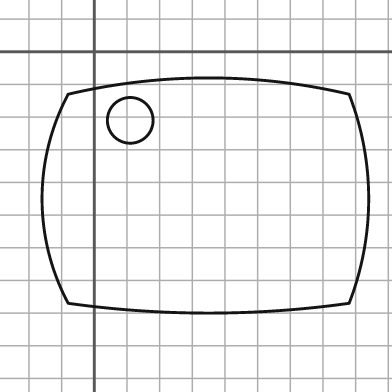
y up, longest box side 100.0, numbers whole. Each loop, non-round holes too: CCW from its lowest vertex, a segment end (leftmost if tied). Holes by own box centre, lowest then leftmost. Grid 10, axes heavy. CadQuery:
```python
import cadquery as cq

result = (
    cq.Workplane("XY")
    .moveTo(-8.0, -77.0)
    .threePointArc((35.0, -80.0), (78.0, -77.0))
    .threePointArc((84.0, -45.0), (78.0, -13.0))
    .threePointArc((35.0, -8.0), (-8.0, -13.0))
    .threePointArc((-16.0, -45.0), (-8.0, -77.0))
    .close()
    .moveTo(11.0, -21.0)
    .circle(7.0)
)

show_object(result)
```